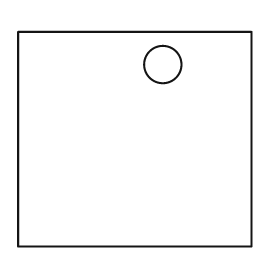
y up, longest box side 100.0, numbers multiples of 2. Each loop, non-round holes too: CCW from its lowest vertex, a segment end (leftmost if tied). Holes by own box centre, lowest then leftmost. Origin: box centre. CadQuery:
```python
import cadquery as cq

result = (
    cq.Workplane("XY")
    .moveTo(-50.0, -46.0)
    .lineTo(50.0, -46.0)
    .lineTo(50.0, 46.0)
    .lineTo(-50.0, 46.0)
    .close()
    .moveTo(12.0, 32.0)
    .circle(8.0)
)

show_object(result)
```